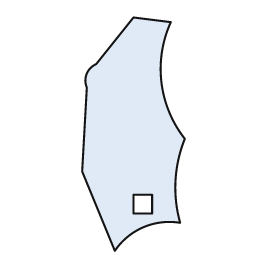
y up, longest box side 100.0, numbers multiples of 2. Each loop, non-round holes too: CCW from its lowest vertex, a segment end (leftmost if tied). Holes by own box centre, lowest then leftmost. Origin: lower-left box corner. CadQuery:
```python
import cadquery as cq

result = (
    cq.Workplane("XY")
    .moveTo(14.0, 0.0)
    .threePointArc((26.0, 10.0), (42.0, 12.0))
    .threePointArc((40.0, 30.0), (44.0, 48.0))
    .threePointArc((34.0, 72.0), (38.0, 98.0))
    .lineTo(22.0, 100.0)
    .lineTo(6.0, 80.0)
    .threePointArc((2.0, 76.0), (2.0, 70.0))
    .lineTo(0.0, 34.0)
    .close()
    .moveTo(22.0, 16.0)
    .lineTo(30.0, 16.0)
    .lineTo(30.0, 24.0)
    .lineTo(22.0, 24.0)
    .close()
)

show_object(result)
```